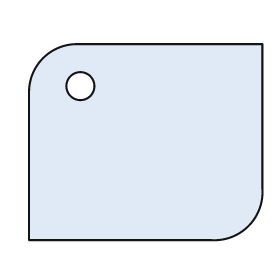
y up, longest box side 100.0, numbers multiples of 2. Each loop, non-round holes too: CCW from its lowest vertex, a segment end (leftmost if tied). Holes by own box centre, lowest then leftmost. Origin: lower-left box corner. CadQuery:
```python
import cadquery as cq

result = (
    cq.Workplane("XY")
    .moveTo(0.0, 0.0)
    .lineTo(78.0, 0.0)
    .threePointArc((94.0, 6.0), (100.0, 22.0))
    .lineTo(100.0, 84.0)
    .lineTo(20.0, 84.0)
    .threePointArc((6.0, 78.0), (0.0, 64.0))
    .close()
    .moveTo(22.0, 66.0)
    .circle(6.0)
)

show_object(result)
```